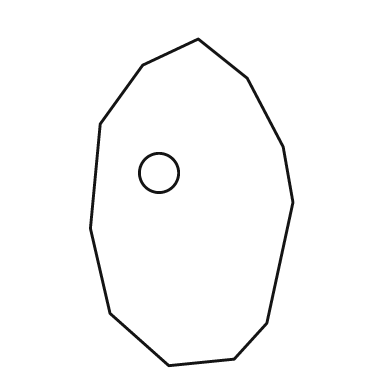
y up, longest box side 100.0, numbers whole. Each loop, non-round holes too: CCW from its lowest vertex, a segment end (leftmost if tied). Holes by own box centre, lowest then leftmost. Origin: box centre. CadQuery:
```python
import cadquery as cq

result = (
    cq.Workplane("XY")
    .moveTo(-7.0, -50.0)
    .lineTo(13.0, -48.0)
    .lineTo(23.0, -37.0)
    .lineTo(31.0, 0.0)
    .lineTo(28.0, 17.0)
    .lineTo(17.0, 38.0)
    .lineTo(2.0, 50.0)
    .lineTo(-15.0, 42.0)
    .lineTo(-28.0, 24.0)
    .lineTo(-31.0, -8.0)
    .lineTo(-25.0, -34.0)
    .close()
    .moveTo(-10.0, 9.0)
    .circle(6.0)
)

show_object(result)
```